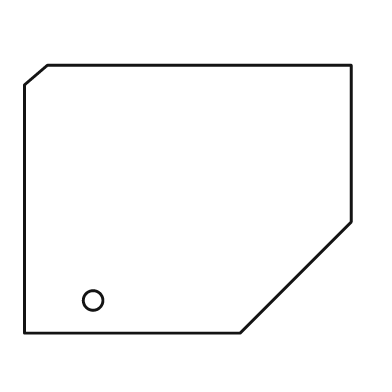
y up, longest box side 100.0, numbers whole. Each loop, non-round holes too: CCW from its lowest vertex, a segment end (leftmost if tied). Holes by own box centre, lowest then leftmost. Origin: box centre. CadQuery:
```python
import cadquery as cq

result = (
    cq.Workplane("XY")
    .moveTo(-50.0, -41.0)
    .lineTo(16.0, -41.0)
    .lineTo(50.0, -7.0)
    .lineTo(50.0, 41.0)
    .lineTo(-43.0, 41.0)
    .lineTo(-50.0, 35.0)
    .close()
    .moveTo(-29.0, -31.0)
    .circle(3.0)
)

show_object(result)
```